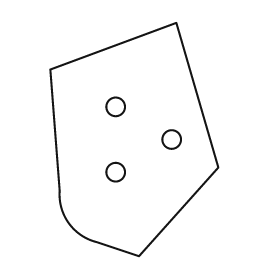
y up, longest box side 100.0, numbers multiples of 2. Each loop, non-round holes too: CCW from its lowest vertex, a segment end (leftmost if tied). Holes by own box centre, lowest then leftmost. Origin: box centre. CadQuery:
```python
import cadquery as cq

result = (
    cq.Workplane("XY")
    .moveTo(2.0, -50.0)
    .lineTo(36.0, -12.0)
    .lineTo(18.0, 50.0)
    .lineTo(-36.0, 30.0)
    .lineTo(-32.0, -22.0)
    .threePointArc((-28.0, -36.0), (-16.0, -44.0))
    .close()
    .moveTo(-8.0, -14.0)
    .circle(4.0)
    .moveTo(16.0, 0.0)
    .circle(4.0)
    .moveTo(-8.0, 14.0)
    .circle(4.0)
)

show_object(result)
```